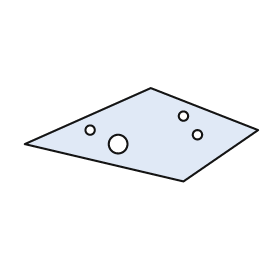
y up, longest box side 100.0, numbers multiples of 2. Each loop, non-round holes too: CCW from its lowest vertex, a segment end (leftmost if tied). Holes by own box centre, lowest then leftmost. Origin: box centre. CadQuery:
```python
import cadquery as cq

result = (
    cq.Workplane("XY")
    .moveTo(18.0, -20.0)
    .lineTo(50.0, 2.0)
    .lineTo(4.0, 20.0)
    .lineTo(-50.0, -4.0)
    .close()
    .moveTo(-10.0, -4.0)
    .circle(4.0)
    .moveTo(24.0, 0.0)
    .circle(2.0)
    .moveTo(-22.0, 2.0)
    .circle(2.0)
    .moveTo(18.0, 8.0)
    .circle(2.0)
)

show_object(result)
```